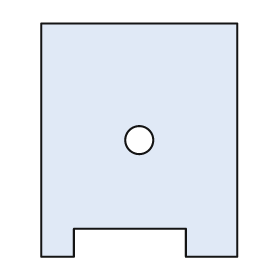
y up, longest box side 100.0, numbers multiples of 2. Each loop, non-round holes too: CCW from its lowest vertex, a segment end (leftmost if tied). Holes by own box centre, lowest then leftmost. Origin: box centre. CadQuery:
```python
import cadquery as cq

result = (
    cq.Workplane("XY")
    .moveTo(-42.0, -50.0)
    .lineTo(-28.0, -50.0)
    .lineTo(-28.0, -38.0)
    .lineTo(20.0, -38.0)
    .lineTo(20.0, -50.0)
    .lineTo(42.0, -50.0)
    .lineTo(42.0, 50.0)
    .lineTo(-42.0, 50.0)
    .close()
    .moveTo(0.0, 0.0)
    .circle(6.0)
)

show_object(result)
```